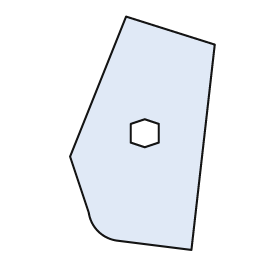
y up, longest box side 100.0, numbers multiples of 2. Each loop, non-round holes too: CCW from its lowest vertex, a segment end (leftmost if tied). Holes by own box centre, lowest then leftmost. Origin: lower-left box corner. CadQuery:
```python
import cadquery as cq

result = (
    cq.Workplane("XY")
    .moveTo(52.0, 0.0)
    .lineTo(62.0, 88.0)
    .lineTo(24.0, 100.0)
    .lineTo(0.0, 40.0)
    .lineTo(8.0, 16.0)
    .threePointArc((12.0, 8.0), (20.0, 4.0))
    .close()
    .moveTo(32.0, 44.0)
    .lineTo(38.0, 46.0)
    .lineTo(38.0, 54.0)
    .lineTo(32.0, 56.0)
    .lineTo(26.0, 54.0)
    .lineTo(26.0, 46.0)
    .close()
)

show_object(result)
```